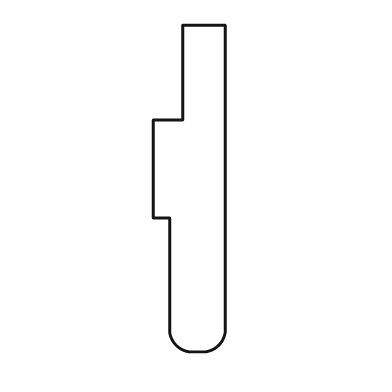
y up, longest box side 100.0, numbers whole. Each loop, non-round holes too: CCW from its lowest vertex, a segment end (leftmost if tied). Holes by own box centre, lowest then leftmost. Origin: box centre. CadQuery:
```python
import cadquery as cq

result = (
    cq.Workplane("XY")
    .moveTo(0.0, -50.0)
    .lineTo(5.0, -50.0)
    .threePointArc((9.0, -48.0), (11.0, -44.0))
    .lineTo(11.0, 50.0)
    .lineTo(-2.0, 50.0)
    .lineTo(-2.0, 21.0)
    .lineTo(-11.0, 21.0)
    .lineTo(-11.0, -9.0)
    .lineTo(-6.0, -9.0)
    .lineTo(-6.0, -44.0)
    .threePointArc((-4.0, -48.0), (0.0, -50.0))
    .close()
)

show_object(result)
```